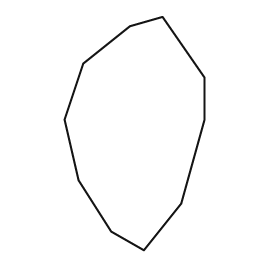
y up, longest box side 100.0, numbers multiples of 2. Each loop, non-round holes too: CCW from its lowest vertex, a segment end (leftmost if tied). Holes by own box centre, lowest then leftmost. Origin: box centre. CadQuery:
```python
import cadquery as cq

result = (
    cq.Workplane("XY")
    .moveTo(4.0, -50.0)
    .lineTo(20.0, -30.0)
    .lineTo(30.0, 6.0)
    .lineTo(30.0, 24.0)
    .lineTo(12.0, 50.0)
    .lineTo(-2.0, 46.0)
    .lineTo(-22.0, 30.0)
    .lineTo(-30.0, 6.0)
    .lineTo(-24.0, -20.0)
    .lineTo(-10.0, -42.0)
    .close()
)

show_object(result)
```